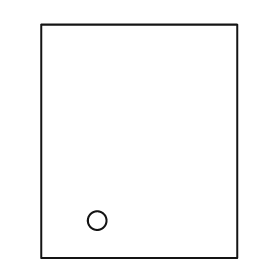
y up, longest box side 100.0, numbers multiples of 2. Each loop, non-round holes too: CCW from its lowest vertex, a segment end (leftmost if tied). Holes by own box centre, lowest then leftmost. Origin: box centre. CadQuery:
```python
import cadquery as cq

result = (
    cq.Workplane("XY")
    .moveTo(-42.0, -50.0)
    .lineTo(42.0, -50.0)
    .lineTo(42.0, 50.0)
    .lineTo(-42.0, 50.0)
    .close()
    .moveTo(-18.0, -34.0)
    .circle(4.0)
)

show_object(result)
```